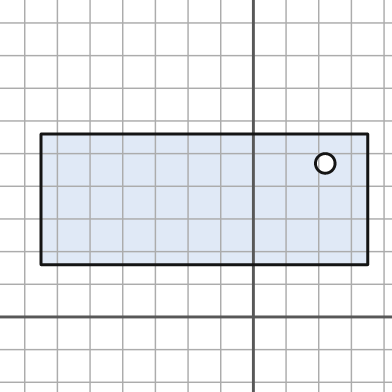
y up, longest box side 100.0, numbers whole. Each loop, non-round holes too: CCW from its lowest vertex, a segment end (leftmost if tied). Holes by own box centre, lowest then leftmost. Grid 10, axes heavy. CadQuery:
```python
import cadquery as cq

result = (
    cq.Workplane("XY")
    .moveTo(-65.0, 16.0)
    .lineTo(35.0, 16.0)
    .lineTo(35.0, 56.0)
    .lineTo(-65.0, 56.0)
    .close()
    .moveTo(22.0, 47.0)
    .circle(3.0)
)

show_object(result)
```